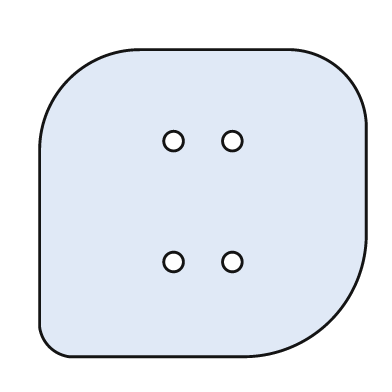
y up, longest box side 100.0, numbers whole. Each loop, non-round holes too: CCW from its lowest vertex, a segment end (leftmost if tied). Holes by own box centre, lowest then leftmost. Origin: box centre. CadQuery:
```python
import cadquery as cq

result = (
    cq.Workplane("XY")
    .moveTo(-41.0, -47.0)
    .lineTo(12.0, -47.0)
    .threePointArc((39.0, -36.0), (50.0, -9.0))
    .lineTo(50.0, 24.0)
    .threePointArc((43.0, 40.0), (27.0, 47.0))
    .lineTo(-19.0, 47.0)
    .threePointArc((-41.0, 38.0), (-50.0, 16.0))
    .lineTo(-50.0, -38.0)
    .threePointArc((-47.0, -44.0), (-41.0, -47.0))
    .close()
    .moveTo(-9.0, -18.0)
    .circle(3.0)
    .moveTo(9.0, -18.0)
    .circle(3.0)
    .moveTo(-9.0, 19.0)
    .circle(3.0)
    .moveTo(9.0, 19.0)
    .circle(3.0)
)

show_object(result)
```